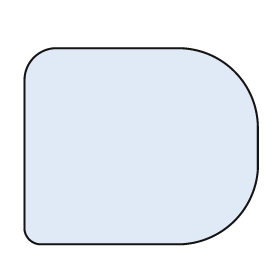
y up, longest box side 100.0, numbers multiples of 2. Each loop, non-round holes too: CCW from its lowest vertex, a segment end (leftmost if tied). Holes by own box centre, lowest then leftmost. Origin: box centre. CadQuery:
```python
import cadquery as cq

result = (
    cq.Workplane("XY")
    .moveTo(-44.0, -42.0)
    .lineTo(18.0, -42.0)
    .threePointArc((40.0, -32.0), (50.0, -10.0))
    .lineTo(50.0, 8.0)
    .threePointArc((40.0, 32.0), (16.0, 42.0))
    .lineTo(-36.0, 42.0)
    .threePointArc((-46.0, 38.0), (-50.0, 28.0))
    .lineTo(-50.0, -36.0)
    .threePointArc((-48.0, -40.0), (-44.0, -42.0))
    .close()
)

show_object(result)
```